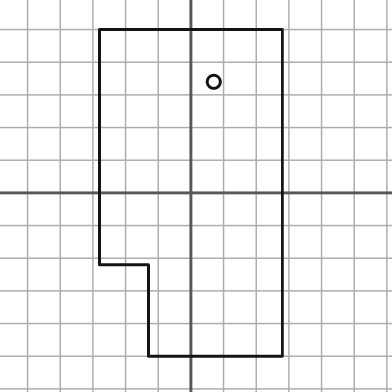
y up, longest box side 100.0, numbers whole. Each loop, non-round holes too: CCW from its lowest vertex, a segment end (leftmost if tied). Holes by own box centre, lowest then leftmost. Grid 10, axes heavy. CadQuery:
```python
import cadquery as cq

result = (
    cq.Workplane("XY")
    .moveTo(-13.0, -50.0)
    .lineTo(28.0, -50.0)
    .lineTo(28.0, 50.0)
    .lineTo(-28.0, 50.0)
    .lineTo(-28.0, -22.0)
    .lineTo(-13.0, -22.0)
    .close()
    .moveTo(7.0, 34.0)
    .circle(2.0)
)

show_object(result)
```